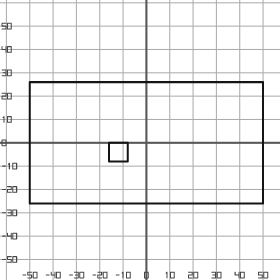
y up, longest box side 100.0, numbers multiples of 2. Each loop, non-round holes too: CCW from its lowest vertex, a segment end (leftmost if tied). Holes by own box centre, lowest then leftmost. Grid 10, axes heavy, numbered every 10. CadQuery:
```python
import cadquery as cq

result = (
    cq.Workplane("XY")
    .moveTo(-50.0, -26.0)
    .lineTo(50.0, -26.0)
    .lineTo(50.0, 26.0)
    .lineTo(-50.0, 26.0)
    .close()
    .moveTo(-16.0, -8.0)
    .lineTo(-8.0, -8.0)
    .lineTo(-8.0, 0.0)
    .lineTo(-16.0, 0.0)
    .close()
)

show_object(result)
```